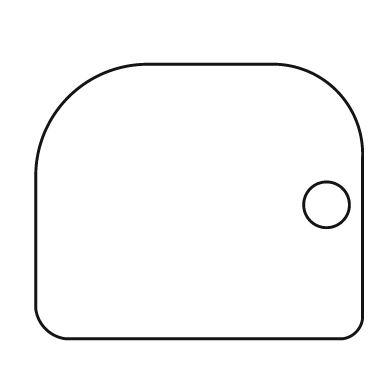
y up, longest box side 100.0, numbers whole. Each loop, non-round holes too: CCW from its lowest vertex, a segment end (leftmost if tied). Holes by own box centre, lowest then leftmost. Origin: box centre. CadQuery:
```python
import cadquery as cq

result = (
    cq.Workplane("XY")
    .moveTo(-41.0, -42.0)
    .lineTo(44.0, -42.0)
    .threePointArc((48.0, -40.0), (50.0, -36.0))
    .lineTo(50.0, 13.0)
    .threePointArc((42.0, 34.0), (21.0, 42.0))
    .lineTo(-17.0, 42.0)
    .threePointArc((-40.0, 32.0), (-50.0, 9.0))
    .lineTo(-50.0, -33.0)
    .threePointArc((-47.0, -39.0), (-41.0, -42.0))
    .close()
    .moveTo(39.0, -1.0)
    .circle(7.0)
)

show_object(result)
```